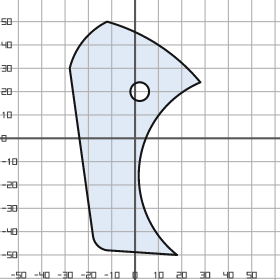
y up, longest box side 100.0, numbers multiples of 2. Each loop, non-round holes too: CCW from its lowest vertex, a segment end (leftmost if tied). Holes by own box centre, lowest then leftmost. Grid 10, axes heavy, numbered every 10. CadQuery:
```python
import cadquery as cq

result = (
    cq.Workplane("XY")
    .moveTo(18.0, -50.0)
    .threePointArc((2.0, -10.0), (28.0, 24.0))
    .threePointArc((10.0, 40.0), (-12.0, 50.0))
    .threePointArc((-22.0, 42.0), (-28.0, 30.0))
    .lineTo(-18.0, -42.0)
    .threePointArc((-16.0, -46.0), (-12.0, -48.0))
    .close()
    .moveTo(2.0, 20.0)
    .circle(4.0)
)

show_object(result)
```